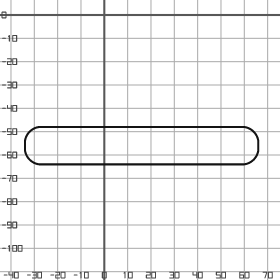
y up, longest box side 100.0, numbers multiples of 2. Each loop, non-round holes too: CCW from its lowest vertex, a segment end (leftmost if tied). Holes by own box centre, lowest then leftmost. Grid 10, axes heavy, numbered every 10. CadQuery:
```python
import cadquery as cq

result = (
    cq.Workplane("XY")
    .moveTo(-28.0, -64.0)
    .lineTo(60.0, -64.0)
    .threePointArc((64.0, -62.0), (66.0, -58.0))
    .lineTo(66.0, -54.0)
    .threePointArc((64.0, -50.0), (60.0, -48.0))
    .lineTo(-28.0, -48.0)
    .threePointArc((-32.0, -50.0), (-34.0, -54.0))
    .lineTo(-34.0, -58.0)
    .threePointArc((-32.0, -62.0), (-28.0, -64.0))
    .close()
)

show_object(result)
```